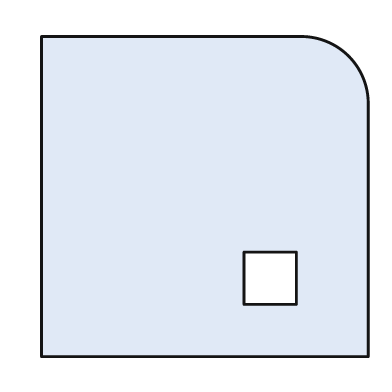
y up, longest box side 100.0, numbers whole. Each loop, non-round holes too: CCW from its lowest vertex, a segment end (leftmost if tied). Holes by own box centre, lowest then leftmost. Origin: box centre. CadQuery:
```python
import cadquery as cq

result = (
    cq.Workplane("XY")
    .moveTo(-50.0, -49.0)
    .lineTo(50.0, -49.0)
    .lineTo(50.0, 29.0)
    .threePointArc((44.0, 43.0), (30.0, 49.0))
    .lineTo(-50.0, 49.0)
    .close()
    .moveTo(12.0, -33.0)
    .lineTo(28.0, -33.0)
    .lineTo(28.0, -17.0)
    .lineTo(12.0, -17.0)
    .close()
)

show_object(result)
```